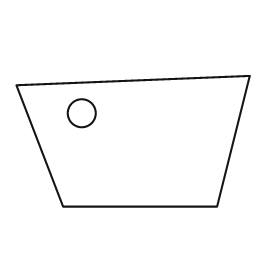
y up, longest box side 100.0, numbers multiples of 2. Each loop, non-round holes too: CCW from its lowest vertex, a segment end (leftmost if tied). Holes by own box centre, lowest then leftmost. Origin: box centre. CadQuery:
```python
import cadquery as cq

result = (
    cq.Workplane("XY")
    .moveTo(-30.0, -28.0)
    .lineTo(36.0, -28.0)
    .lineTo(50.0, 28.0)
    .lineTo(-50.0, 24.0)
    .close()
    .moveTo(-22.0, 12.0)
    .circle(6.0)
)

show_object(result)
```